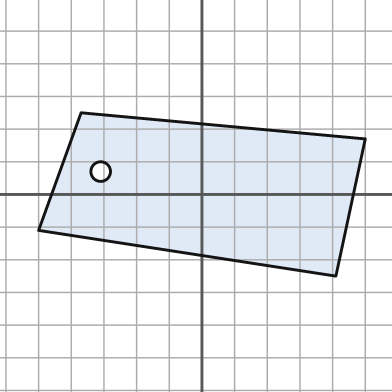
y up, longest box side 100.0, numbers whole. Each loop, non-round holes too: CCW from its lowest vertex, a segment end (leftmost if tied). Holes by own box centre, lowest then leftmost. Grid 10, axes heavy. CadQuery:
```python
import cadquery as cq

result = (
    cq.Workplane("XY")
    .moveTo(41.0, -25.0)
    .lineTo(50.0, 17.0)
    .lineTo(-37.0, 25.0)
    .lineTo(-50.0, -11.0)
    .close()
    .moveTo(-31.0, 7.0)
    .circle(3.0)
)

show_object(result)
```